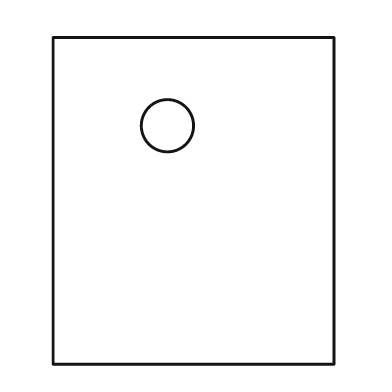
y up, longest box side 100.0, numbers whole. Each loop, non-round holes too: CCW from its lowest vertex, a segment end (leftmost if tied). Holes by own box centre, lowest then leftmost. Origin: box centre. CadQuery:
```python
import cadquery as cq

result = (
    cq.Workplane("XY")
    .moveTo(-43.0, -50.0)
    .lineTo(43.0, -50.0)
    .lineTo(43.0, 50.0)
    .lineTo(-43.0, 50.0)
    .close()
    .moveTo(-8.0, 23.0)
    .circle(8.0)
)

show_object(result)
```